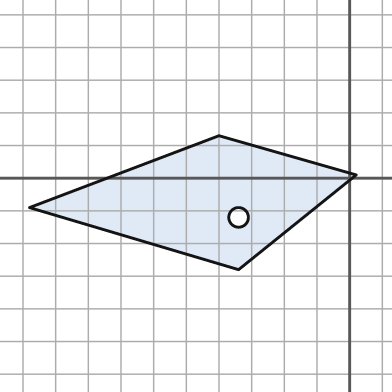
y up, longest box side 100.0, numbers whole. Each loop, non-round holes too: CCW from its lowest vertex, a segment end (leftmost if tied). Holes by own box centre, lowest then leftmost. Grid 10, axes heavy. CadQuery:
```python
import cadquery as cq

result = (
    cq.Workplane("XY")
    .moveTo(-34.0, -28.0)
    .lineTo(2.0, 1.0)
    .lineTo(-40.0, 13.0)
    .lineTo(-98.0, -9.0)
    .close()
    .moveTo(-34.0, -12.0)
    .circle(3.0)
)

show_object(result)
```